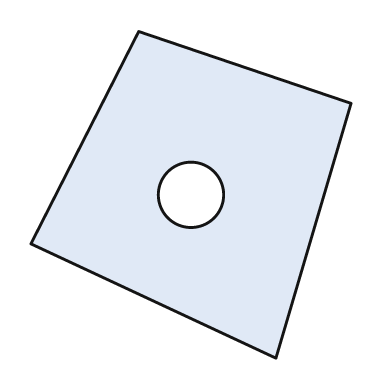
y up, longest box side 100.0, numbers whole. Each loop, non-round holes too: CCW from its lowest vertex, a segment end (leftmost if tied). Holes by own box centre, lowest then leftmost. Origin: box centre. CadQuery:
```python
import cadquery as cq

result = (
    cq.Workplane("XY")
    .moveTo(26.0, -50.0)
    .lineTo(49.0, 28.0)
    .lineTo(-16.0, 50.0)
    .lineTo(-49.0, -15.0)
    .close()
    .moveTo(0.0, 0.0)
    .circle(10.0)
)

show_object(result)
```